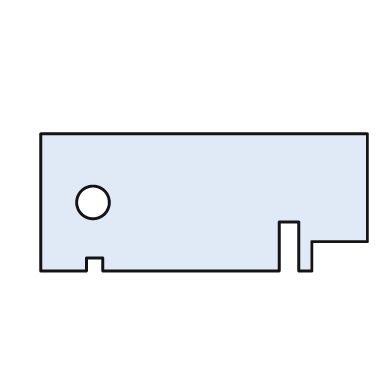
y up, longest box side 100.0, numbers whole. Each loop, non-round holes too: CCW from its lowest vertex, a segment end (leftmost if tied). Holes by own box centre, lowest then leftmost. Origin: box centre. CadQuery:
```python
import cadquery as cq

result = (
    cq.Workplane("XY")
    .moveTo(-50.0, -21.0)
    .lineTo(-36.0, -21.0)
    .lineTo(-36.0, -17.0)
    .lineTo(-31.0, -17.0)
    .lineTo(-31.0, -21.0)
    .lineTo(23.0, -21.0)
    .lineTo(23.0, -6.0)
    .lineTo(29.0, -6.0)
    .lineTo(29.0, -21.0)
    .lineTo(33.0, -21.0)
    .lineTo(33.0, -12.0)
    .lineTo(50.0, -12.0)
    .lineTo(50.0, 21.0)
    .lineTo(-50.0, 21.0)
    .close()
    .moveTo(-34.0, 0.0)
    .circle(5.0)
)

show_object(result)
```